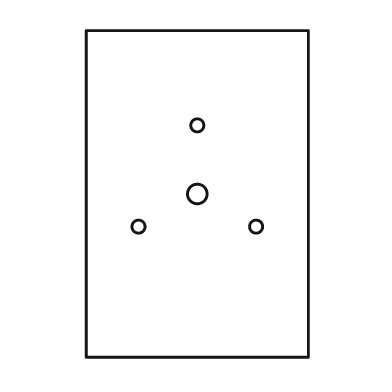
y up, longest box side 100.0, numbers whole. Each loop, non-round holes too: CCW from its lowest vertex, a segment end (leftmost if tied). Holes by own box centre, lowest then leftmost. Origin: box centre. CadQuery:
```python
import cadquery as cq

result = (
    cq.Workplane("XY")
    .moveTo(-34.0, -50.0)
    .lineTo(34.0, -50.0)
    .lineTo(34.0, 50.0)
    .lineTo(-34.0, 50.0)
    .close()
    .moveTo(-18.0, -10.0)
    .circle(2.0)
    .moveTo(18.0, -10.0)
    .circle(2.0)
    .moveTo(0.0, 0.0)
    .circle(3.0)
    .moveTo(0.0, 21.0)
    .circle(2.0)
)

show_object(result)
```